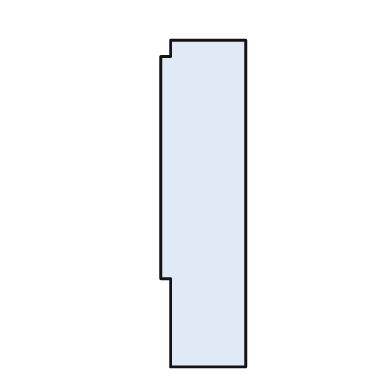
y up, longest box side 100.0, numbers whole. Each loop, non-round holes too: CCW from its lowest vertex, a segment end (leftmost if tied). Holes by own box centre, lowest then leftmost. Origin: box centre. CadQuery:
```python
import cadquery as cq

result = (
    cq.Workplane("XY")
    .moveTo(-10.0, -50.0)
    .lineTo(13.0, -50.0)
    .lineTo(13.0, 50.0)
    .lineTo(-10.0, 50.0)
    .lineTo(-10.0, 45.0)
    .lineTo(-13.0, 45.0)
    .lineTo(-13.0, -23.0)
    .lineTo(-10.0, -23.0)
    .close()
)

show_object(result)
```